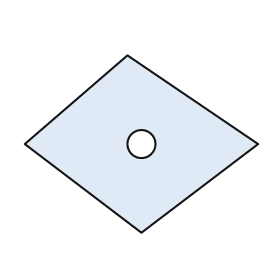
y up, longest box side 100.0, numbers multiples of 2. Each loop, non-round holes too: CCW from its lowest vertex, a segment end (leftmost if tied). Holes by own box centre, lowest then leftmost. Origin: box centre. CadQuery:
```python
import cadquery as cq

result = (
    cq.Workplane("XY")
    .moveTo(0.0, -38.0)
    .lineTo(50.0, 0.0)
    .lineTo(-6.0, 38.0)
    .lineTo(-50.0, 0.0)
    .close()
    .moveTo(0.0, 0.0)
    .circle(6.0)
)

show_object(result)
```